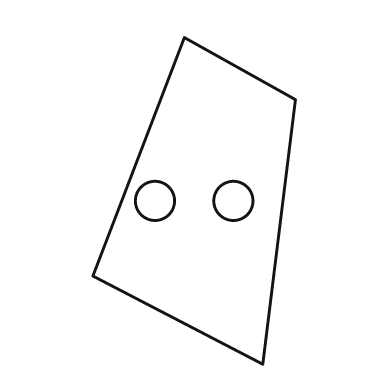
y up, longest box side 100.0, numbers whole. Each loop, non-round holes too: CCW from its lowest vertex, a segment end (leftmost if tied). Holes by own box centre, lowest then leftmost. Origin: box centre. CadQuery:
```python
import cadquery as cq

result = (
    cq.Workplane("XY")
    .moveTo(21.0, -50.0)
    .lineTo(31.0, 31.0)
    .lineTo(-3.0, 50.0)
    .lineTo(-31.0, -23.0)
    .close()
    .moveTo(-12.0, 0.0)
    .circle(6.0)
    .moveTo(12.0, 0.0)
    .circle(6.0)
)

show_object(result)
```